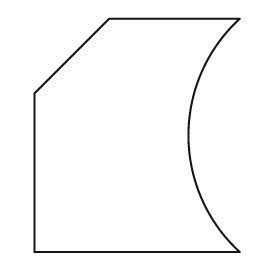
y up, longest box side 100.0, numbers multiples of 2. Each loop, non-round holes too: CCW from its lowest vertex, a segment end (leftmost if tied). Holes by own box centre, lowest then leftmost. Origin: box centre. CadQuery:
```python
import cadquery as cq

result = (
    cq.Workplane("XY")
    .moveTo(-44.0, -50.0)
    .lineTo(44.0, -50.0)
    .threePointArc((22.0, 0.0), (44.0, 50.0))
    .lineTo(-12.0, 50.0)
    .lineTo(-44.0, 18.0)
    .close()
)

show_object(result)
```